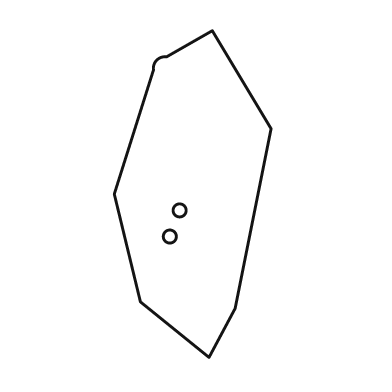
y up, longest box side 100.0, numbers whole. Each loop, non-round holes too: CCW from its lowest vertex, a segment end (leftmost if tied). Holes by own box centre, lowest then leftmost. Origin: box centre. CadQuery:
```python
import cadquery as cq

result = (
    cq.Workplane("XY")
    .moveTo(5.0, -50.0)
    .lineTo(13.0, -35.0)
    .lineTo(24.0, 20.0)
    .lineTo(6.0, 50.0)
    .lineTo(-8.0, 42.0)
    .threePointArc((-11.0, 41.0), (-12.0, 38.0))
    .lineTo(-24.0, 0.0)
    .lineTo(-16.0, -33.0)
    .close()
    .moveTo(-7.0, -13.0)
    .circle(2.0)
    .moveTo(-4.0, -5.0)
    .circle(2.0)
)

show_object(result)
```